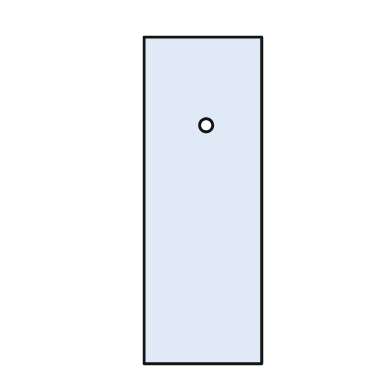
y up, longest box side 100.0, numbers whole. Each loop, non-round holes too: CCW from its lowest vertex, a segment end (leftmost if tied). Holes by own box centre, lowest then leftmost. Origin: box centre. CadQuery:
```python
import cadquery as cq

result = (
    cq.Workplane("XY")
    .moveTo(-18.0, -50.0)
    .lineTo(18.0, -50.0)
    .lineTo(18.0, 50.0)
    .lineTo(-18.0, 50.0)
    .close()
    .moveTo(1.0, 23.0)
    .circle(2.0)
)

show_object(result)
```